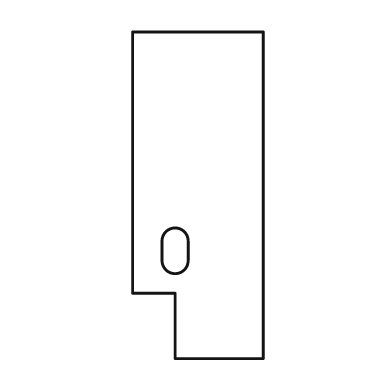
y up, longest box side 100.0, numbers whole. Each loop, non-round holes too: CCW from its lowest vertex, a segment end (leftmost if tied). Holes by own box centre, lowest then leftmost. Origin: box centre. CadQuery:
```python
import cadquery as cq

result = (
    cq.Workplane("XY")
    .moveTo(-7.0, -50.0)
    .lineTo(20.0, -50.0)
    .lineTo(20.0, 50.0)
    .lineTo(-20.0, 50.0)
    .lineTo(-20.0, -30.0)
    .lineTo(-7.0, -30.0)
    .close()
    .moveTo(-11.0, -20.0)
    .threePointArc((-7.0, -24.0), (-3.0, -20.0))
    .lineTo(-3.0, -14.0)
    .threePointArc((-7.0, -10.0), (-11.0, -14.0))
    .close()
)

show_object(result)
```